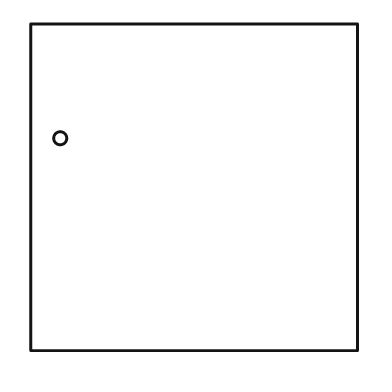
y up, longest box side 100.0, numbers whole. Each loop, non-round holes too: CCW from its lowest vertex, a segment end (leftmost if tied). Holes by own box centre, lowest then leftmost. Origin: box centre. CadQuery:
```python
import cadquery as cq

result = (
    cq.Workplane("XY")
    .moveTo(-50.0, -50.0)
    .lineTo(50.0, -50.0)
    .lineTo(50.0, 50.0)
    .lineTo(-50.0, 50.0)
    .close()
    .moveTo(-41.0, 15.0)
    .circle(2.0)
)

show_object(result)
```